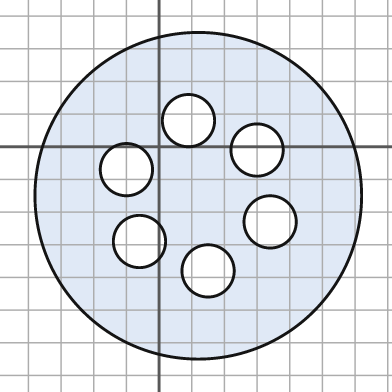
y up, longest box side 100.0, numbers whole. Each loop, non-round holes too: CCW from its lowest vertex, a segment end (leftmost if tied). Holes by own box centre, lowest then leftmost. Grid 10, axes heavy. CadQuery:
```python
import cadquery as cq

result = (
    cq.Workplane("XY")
    .moveTo(12.0, -15.0)
    .circle(50.0)
    .moveTo(15.0, -38.0)
    .circle(8.0)
    .moveTo(-6.0, -29.0)
    .circle(8.0)
    .moveTo(34.0, -23.0)
    .circle(8.0)
    .moveTo(-10.0, -7.0)
    .circle(8.0)
    .moveTo(30.0, -1.0)
    .circle(8.0)
    .moveTo(9.0, 8.0)
    .circle(8.0)
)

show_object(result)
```